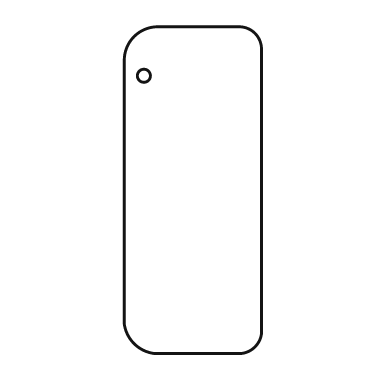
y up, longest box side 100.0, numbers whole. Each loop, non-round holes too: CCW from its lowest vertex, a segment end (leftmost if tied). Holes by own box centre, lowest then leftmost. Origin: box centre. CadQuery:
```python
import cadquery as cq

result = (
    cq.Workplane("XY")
    .moveTo(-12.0, -50.0)
    .lineTo(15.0, -50.0)
    .threePointArc((19.0, -48.0), (21.0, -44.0))
    .lineTo(21.0, 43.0)
    .threePointArc((19.0, 48.0), (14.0, 50.0))
    .lineTo(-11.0, 50.0)
    .threePointArc((-18.0, 47.0), (-21.0, 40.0))
    .lineTo(-21.0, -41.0)
    .threePointArc((-18.0, -47.0), (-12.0, -50.0))
    .close()
    .moveTo(-15.0, 35.0)
    .circle(2.0)
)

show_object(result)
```